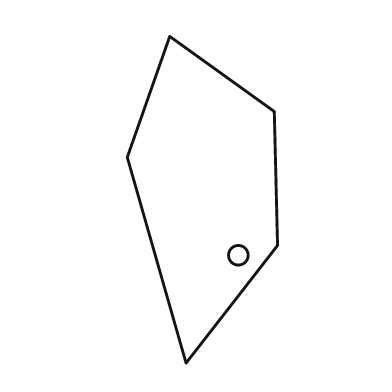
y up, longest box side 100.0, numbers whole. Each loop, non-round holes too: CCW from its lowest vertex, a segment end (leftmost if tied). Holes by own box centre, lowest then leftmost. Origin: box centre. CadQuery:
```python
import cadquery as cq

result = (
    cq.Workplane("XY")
    .moveTo(-5.0, -50.0)
    .lineTo(23.0, -14.0)
    .lineTo(22.0, 27.0)
    .lineTo(-10.0, 50.0)
    .lineTo(-23.0, 13.0)
    .close()
    .moveTo(11.0, -17.0)
    .circle(3.0)
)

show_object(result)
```